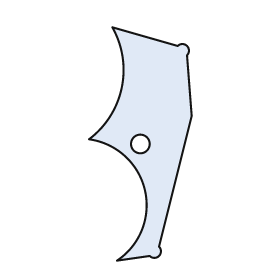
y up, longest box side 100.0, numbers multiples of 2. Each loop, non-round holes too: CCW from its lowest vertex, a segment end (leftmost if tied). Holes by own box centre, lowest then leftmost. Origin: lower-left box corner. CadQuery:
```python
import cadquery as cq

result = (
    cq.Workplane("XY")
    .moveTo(12.0, 0.0)
    .lineTo(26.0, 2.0)
    .threePointArc((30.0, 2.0), (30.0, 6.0))
    .lineTo(44.0, 62.0)
    .lineTo(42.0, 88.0)
    .threePointArc((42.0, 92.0), (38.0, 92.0))
    .lineTo(10.0, 100.0)
    .threePointArc((14.0, 74.0), (0.0, 52.0))
    .threePointArc((24.0, 30.0), (12.0, 0.0))
    .close()
    .moveTo(22.0, 50.0)
    .circle(4.0)
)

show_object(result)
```